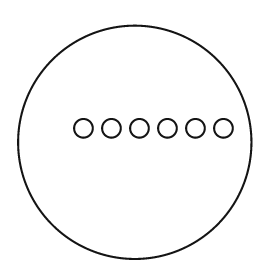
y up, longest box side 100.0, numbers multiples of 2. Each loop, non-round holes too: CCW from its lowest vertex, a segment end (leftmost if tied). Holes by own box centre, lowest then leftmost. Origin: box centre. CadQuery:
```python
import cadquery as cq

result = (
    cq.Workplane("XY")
    .moveTo(0.0, 0.0)
    .circle(50.0)
    .moveTo(-22.0, 6.0)
    .circle(4.0)
    .moveTo(-10.0, 6.0)
    .circle(4.0)
    .moveTo(2.0, 6.0)
    .circle(4.0)
    .moveTo(14.0, 6.0)
    .circle(4.0)
    .moveTo(26.0, 6.0)
    .circle(4.0)
    .moveTo(38.0, 6.0)
    .circle(4.0)
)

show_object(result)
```